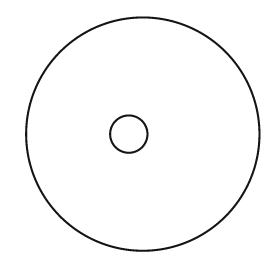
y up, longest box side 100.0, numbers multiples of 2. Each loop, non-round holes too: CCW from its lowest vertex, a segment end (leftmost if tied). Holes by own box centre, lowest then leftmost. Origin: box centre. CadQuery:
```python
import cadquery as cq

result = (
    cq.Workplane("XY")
    .moveTo(0.0, 0.0)
    .circle(50.0)
    .moveTo(-6.0, 0.0)
    .circle(8.0)
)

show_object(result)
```